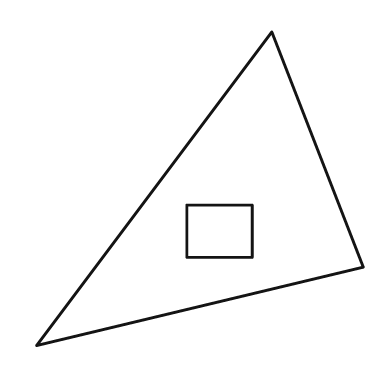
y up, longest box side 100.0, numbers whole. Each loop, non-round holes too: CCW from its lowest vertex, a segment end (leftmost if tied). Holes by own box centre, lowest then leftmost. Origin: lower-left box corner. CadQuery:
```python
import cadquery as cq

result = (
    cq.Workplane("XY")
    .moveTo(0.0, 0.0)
    .lineTo(100.0, 24.0)
    .lineTo(72.0, 96.0)
    .close()
    .moveTo(46.0, 27.0)
    .lineTo(66.0, 27.0)
    .lineTo(66.0, 43.0)
    .lineTo(46.0, 43.0)
    .close()
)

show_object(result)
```